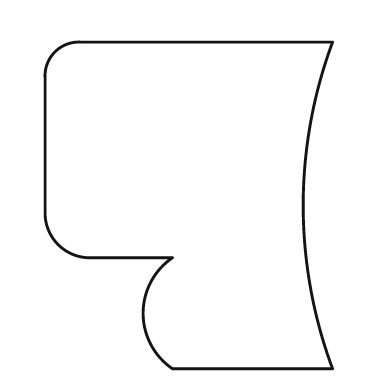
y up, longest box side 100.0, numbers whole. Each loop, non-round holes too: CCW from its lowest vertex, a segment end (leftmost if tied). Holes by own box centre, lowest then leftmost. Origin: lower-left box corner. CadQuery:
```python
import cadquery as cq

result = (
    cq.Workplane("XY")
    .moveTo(39.0, 0.0)
    .lineTo(88.0, 0.0)
    .threePointArc((79.0, 50.0), (88.0, 100.0))
    .lineTo(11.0, 100.0)
    .threePointArc((3.0, 97.0), (0.0, 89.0))
    .lineTo(0.0, 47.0)
    .threePointArc((4.0, 38.0), (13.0, 34.0))
    .lineTo(39.0, 34.0)
    .threePointArc((30.0, 17.0), (39.0, 0.0))
    .close()
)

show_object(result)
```